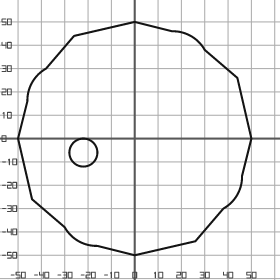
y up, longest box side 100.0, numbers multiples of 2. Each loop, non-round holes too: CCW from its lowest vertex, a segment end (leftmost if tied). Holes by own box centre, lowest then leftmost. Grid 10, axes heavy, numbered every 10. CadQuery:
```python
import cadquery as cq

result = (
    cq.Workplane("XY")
    .moveTo(0.0, -50.0)
    .lineTo(26.0, -44.0)
    .lineTo(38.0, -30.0)
    .threePointArc((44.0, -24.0), (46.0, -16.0))
    .lineTo(50.0, 0.0)
    .lineTo(44.0, 26.0)
    .lineTo(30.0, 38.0)
    .threePointArc((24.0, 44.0), (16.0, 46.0))
    .lineTo(0.0, 50.0)
    .lineTo(-26.0, 44.0)
    .lineTo(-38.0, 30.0)
    .threePointArc((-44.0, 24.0), (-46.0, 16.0))
    .lineTo(-50.0, 0.0)
    .lineTo(-44.0, -26.0)
    .lineTo(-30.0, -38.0)
    .threePointArc((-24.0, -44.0), (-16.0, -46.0))
    .close()
    .moveTo(-22.0, -6.0)
    .circle(6.0)
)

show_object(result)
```